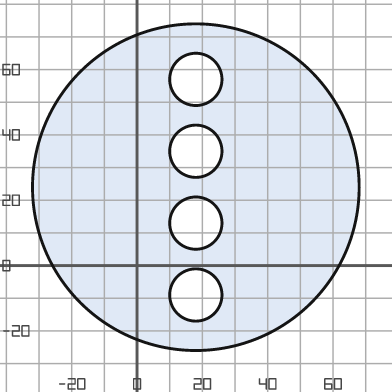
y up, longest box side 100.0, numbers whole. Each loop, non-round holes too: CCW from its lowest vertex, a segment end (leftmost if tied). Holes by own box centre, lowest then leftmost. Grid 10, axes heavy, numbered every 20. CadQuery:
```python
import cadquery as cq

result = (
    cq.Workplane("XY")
    .moveTo(18.0, 24.0)
    .circle(50.0)
    .moveTo(18.0, -9.0)
    .circle(8.0)
    .moveTo(18.0, 13.0)
    .circle(8.0)
    .moveTo(18.0, 35.0)
    .circle(8.0)
    .moveTo(18.0, 57.0)
    .circle(8.0)
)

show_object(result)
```